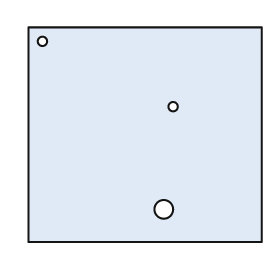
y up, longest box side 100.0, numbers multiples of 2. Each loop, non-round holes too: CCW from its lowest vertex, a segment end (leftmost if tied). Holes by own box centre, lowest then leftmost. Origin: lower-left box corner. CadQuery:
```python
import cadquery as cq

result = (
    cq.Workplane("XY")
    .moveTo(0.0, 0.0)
    .lineTo(100.0, 0.0)
    .lineTo(100.0, 92.0)
    .lineTo(0.0, 92.0)
    .close()
    .moveTo(58.0, 14.0)
    .circle(4.0)
    .moveTo(62.0, 58.0)
    .circle(2.0)
    .moveTo(6.0, 86.0)
    .circle(2.0)
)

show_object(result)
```